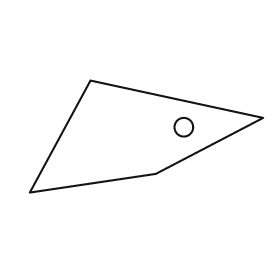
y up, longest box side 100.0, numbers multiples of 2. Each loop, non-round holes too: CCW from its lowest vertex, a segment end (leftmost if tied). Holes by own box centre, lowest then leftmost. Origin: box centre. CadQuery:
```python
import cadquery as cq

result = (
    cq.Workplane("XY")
    .moveTo(-50.0, -24.0)
    .lineTo(4.0, -16.0)
    .lineTo(50.0, 8.0)
    .lineTo(-24.0, 24.0)
    .close()
    .moveTo(16.0, 4.0)
    .circle(4.0)
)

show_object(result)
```